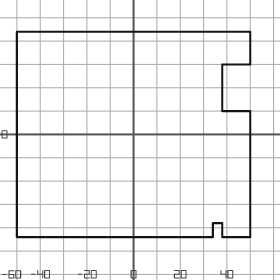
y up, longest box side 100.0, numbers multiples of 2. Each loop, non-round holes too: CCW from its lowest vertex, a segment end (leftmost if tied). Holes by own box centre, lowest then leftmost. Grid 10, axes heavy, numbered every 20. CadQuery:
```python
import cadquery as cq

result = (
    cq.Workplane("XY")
    .moveTo(-50.0, -44.0)
    .lineTo(34.0, -44.0)
    .lineTo(34.0, -38.0)
    .lineTo(38.0, -38.0)
    .lineTo(38.0, -44.0)
    .lineTo(50.0, -44.0)
    .lineTo(50.0, 10.0)
    .lineTo(38.0, 10.0)
    .lineTo(38.0, 30.0)
    .lineTo(50.0, 30.0)
    .lineTo(50.0, 44.0)
    .lineTo(-50.0, 44.0)
    .close()
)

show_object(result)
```